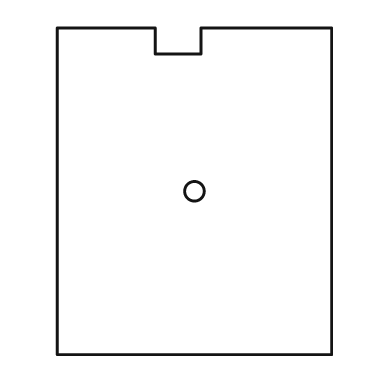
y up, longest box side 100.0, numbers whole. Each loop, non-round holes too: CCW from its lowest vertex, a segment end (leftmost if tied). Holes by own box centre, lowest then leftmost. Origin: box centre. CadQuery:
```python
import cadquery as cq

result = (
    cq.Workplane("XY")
    .moveTo(-42.0, -50.0)
    .lineTo(42.0, -50.0)
    .lineTo(42.0, 50.0)
    .lineTo(2.0, 50.0)
    .lineTo(2.0, 42.0)
    .lineTo(-12.0, 42.0)
    .lineTo(-12.0, 50.0)
    .lineTo(-42.0, 50.0)
    .close()
    .moveTo(0.0, 0.0)
    .circle(3.0)
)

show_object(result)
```